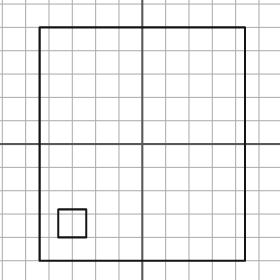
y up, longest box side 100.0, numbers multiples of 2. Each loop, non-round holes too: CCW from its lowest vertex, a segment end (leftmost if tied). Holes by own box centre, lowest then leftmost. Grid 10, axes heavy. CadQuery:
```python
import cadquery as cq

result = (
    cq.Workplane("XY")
    .moveTo(-44.0, -50.0)
    .lineTo(44.0, -50.0)
    .lineTo(44.0, 50.0)
    .lineTo(-44.0, 50.0)
    .close()
    .moveTo(-36.0, -40.0)
    .lineTo(-24.0, -40.0)
    .lineTo(-24.0, -28.0)
    .lineTo(-36.0, -28.0)
    .close()
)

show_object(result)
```